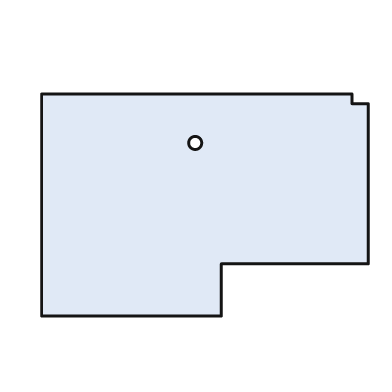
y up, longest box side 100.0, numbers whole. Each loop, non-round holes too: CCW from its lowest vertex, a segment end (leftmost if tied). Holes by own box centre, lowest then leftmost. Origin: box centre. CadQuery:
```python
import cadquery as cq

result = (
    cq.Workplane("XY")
    .moveTo(-50.0, -34.0)
    .lineTo(5.0, -34.0)
    .lineTo(5.0, -18.0)
    .lineTo(50.0, -18.0)
    .lineTo(50.0, 31.0)
    .lineTo(45.0, 31.0)
    .lineTo(45.0, 34.0)
    .lineTo(-50.0, 34.0)
    .close()
    .moveTo(-3.0, 19.0)
    .circle(2.0)
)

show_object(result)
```